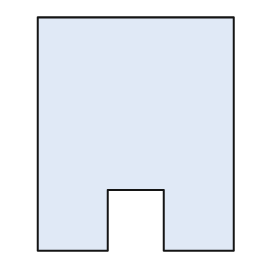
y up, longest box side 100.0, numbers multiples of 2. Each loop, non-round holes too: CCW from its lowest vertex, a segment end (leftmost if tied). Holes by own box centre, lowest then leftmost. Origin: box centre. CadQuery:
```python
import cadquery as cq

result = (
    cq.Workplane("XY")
    .moveTo(-42.0, -50.0)
    .lineTo(-12.0, -50.0)
    .lineTo(-12.0, -24.0)
    .lineTo(12.0, -24.0)
    .lineTo(12.0, -50.0)
    .lineTo(42.0, -50.0)
    .lineTo(42.0, 50.0)
    .lineTo(-42.0, 50.0)
    .close()
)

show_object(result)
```